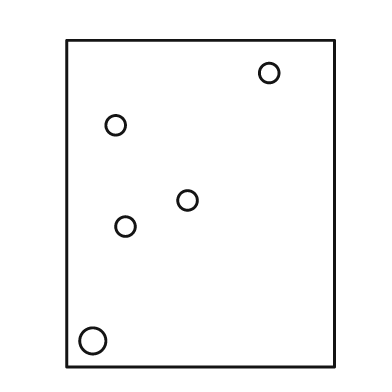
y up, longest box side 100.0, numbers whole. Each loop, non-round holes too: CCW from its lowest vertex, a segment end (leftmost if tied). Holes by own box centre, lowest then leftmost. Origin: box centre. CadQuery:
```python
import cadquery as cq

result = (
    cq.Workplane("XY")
    .moveTo(-41.0, -50.0)
    .lineTo(41.0, -50.0)
    .lineTo(41.0, 50.0)
    .lineTo(-41.0, 50.0)
    .close()
    .moveTo(-33.0, -42.0)
    .circle(4.0)
    .moveTo(-23.0, -7.0)
    .circle(3.0)
    .moveTo(-4.0, 1.0)
    .circle(3.0)
    .moveTo(-26.0, 24.0)
    .circle(3.0)
    .moveTo(21.0, 40.0)
    .circle(3.0)
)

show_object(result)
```